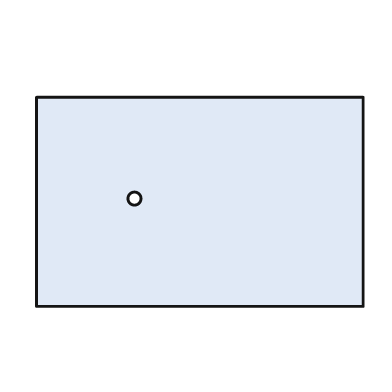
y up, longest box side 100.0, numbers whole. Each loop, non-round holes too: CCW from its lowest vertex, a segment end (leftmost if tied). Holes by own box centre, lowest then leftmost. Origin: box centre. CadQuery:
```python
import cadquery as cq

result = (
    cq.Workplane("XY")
    .moveTo(-50.0, -32.0)
    .lineTo(50.0, -32.0)
    .lineTo(50.0, 32.0)
    .lineTo(-50.0, 32.0)
    .close()
    .moveTo(-20.0, 1.0)
    .circle(2.0)
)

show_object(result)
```